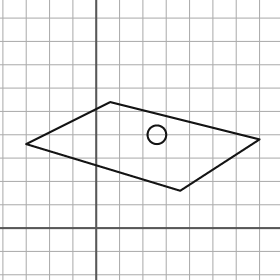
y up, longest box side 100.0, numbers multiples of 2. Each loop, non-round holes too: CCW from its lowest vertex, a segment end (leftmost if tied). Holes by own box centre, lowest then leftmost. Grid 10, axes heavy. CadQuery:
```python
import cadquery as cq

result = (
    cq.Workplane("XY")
    .moveTo(36.0, 16.0)
    .lineTo(70.0, 38.0)
    .lineTo(6.0, 54.0)
    .lineTo(-30.0, 36.0)
    .close()
    .moveTo(26.0, 40.0)
    .circle(4.0)
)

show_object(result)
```